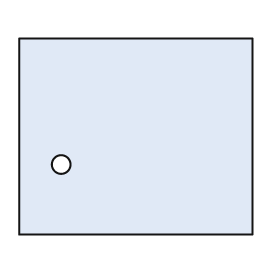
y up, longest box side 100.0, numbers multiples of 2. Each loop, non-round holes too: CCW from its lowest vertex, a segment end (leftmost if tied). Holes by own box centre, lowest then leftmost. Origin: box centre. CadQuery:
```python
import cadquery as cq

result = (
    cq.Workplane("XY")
    .moveTo(-50.0, -42.0)
    .lineTo(50.0, -42.0)
    .lineTo(50.0, 42.0)
    .lineTo(-50.0, 42.0)
    .close()
    .moveTo(-32.0, -12.0)
    .circle(4.0)
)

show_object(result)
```